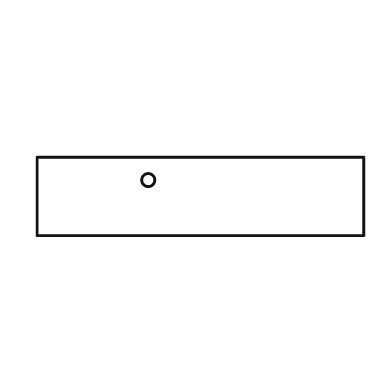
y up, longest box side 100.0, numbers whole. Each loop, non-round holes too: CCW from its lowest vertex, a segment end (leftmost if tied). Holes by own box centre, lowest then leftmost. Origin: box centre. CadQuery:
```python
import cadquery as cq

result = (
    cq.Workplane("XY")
    .moveTo(-50.0, -12.0)
    .lineTo(50.0, -12.0)
    .lineTo(50.0, 12.0)
    .lineTo(-50.0, 12.0)
    .close()
    .moveTo(-16.0, 5.0)
    .circle(2.0)
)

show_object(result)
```